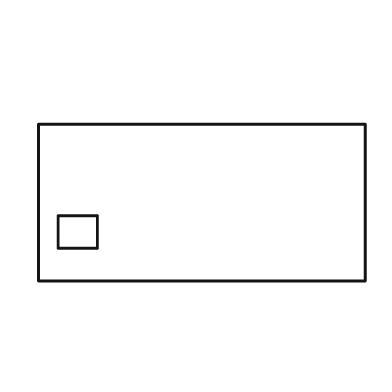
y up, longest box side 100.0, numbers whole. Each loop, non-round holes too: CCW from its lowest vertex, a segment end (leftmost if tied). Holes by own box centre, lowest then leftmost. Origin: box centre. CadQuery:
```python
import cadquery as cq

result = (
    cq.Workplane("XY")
    .moveTo(-50.0, -24.0)
    .lineTo(50.0, -24.0)
    .lineTo(50.0, 24.0)
    .lineTo(-50.0, 24.0)
    .close()
    .moveTo(-44.0, -14.0)
    .lineTo(-32.0, -14.0)
    .lineTo(-32.0, -4.0)
    .lineTo(-44.0, -4.0)
    .close()
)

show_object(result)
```